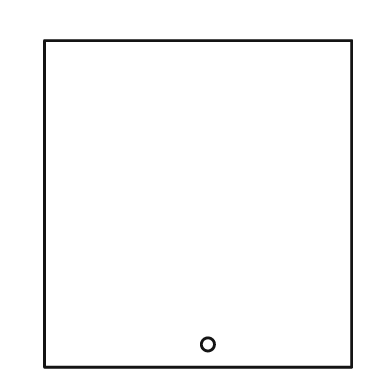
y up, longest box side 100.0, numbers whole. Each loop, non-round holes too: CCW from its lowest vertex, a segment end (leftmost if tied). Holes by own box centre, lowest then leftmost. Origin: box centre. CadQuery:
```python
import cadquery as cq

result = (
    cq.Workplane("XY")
    .moveTo(-47.0, -50.0)
    .lineTo(47.0, -50.0)
    .lineTo(47.0, 50.0)
    .lineTo(-47.0, 50.0)
    .close()
    .moveTo(3.0, -43.0)
    .circle(2.0)
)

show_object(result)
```